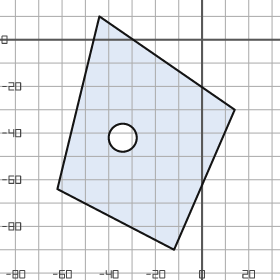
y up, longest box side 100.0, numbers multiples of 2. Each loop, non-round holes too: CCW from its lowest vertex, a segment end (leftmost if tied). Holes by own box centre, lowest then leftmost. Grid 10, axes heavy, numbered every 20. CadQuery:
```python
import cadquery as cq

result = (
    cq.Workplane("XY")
    .moveTo(-12.0, -90.0)
    .lineTo(14.0, -30.0)
    .lineTo(-44.0, 10.0)
    .lineTo(-62.0, -64.0)
    .close()
    .moveTo(-34.0, -42.0)
    .circle(6.0)
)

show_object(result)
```